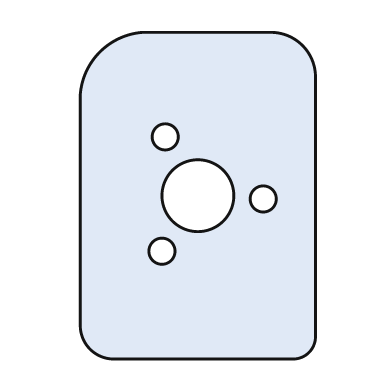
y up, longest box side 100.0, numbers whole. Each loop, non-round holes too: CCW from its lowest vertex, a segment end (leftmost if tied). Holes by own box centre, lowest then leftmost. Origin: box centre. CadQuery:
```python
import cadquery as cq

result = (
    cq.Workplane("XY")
    .moveTo(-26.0, -50.0)
    .lineTo(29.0, -50.0)
    .threePointArc((34.0, -48.0), (36.0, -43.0))
    .lineTo(36.0, 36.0)
    .threePointArc((32.0, 46.0), (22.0, 50.0))
    .lineTo(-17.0, 50.0)
    .threePointArc((-30.0, 44.0), (-36.0, 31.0))
    .lineTo(-36.0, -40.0)
    .threePointArc((-33.0, -47.0), (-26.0, -50.0))
    .close()
    .moveTo(-11.0, -17.0)
    .circle(4.0)
    .moveTo(20.0, -1.0)
    .circle(4.0)
    .moveTo(0.0, 0.0)
    .circle(11.0)
    .moveTo(-10.0, 18.0)
    .circle(4.0)
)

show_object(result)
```